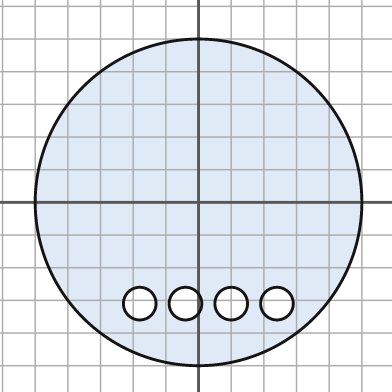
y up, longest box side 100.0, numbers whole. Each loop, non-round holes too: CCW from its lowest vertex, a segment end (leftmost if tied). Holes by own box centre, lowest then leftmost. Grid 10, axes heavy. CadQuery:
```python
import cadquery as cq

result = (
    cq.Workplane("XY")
    .moveTo(0.0, 0.0)
    .circle(50.0)
    .moveTo(-18.0, -31.0)
    .circle(5.0)
    .moveTo(-4.0, -31.0)
    .circle(5.0)
    .moveTo(10.0, -31.0)
    .circle(5.0)
    .moveTo(24.0, -31.0)
    .circle(5.0)
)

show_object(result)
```